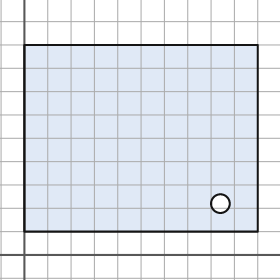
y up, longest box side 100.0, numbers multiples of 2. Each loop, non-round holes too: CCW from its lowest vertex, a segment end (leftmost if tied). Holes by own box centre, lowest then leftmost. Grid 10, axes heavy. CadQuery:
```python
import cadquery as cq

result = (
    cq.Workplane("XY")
    .moveTo(0.0, 10.0)
    .lineTo(100.0, 10.0)
    .lineTo(100.0, 90.0)
    .lineTo(0.0, 90.0)
    .close()
    .moveTo(84.0, 22.0)
    .circle(4.0)
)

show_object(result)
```